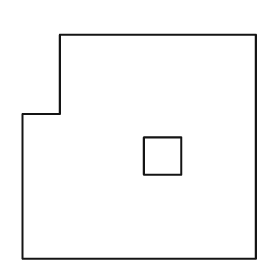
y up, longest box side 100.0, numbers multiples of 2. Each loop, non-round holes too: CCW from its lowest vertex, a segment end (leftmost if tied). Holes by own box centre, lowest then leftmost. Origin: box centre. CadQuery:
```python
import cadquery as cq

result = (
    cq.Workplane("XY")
    .moveTo(-50.0, -48.0)
    .lineTo(50.0, -48.0)
    .lineTo(50.0, 48.0)
    .lineTo(-34.0, 48.0)
    .lineTo(-34.0, 14.0)
    .lineTo(-50.0, 14.0)
    .close()
    .moveTo(2.0, -12.0)
    .lineTo(18.0, -12.0)
    .lineTo(18.0, 4.0)
    .lineTo(2.0, 4.0)
    .close()
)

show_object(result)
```